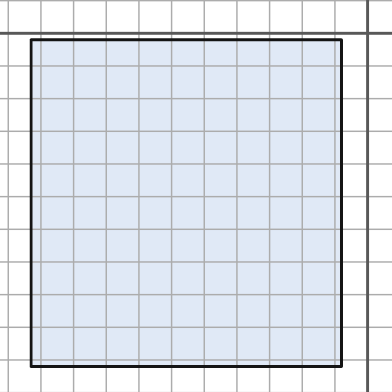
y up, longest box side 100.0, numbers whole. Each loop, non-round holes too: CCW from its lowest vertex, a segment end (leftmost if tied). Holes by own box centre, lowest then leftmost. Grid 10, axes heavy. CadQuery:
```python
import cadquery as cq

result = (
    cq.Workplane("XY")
    .moveTo(-103.0, -102.0)
    .lineTo(-8.0, -102.0)
    .lineTo(-8.0, -2.0)
    .lineTo(-103.0, -2.0)
    .close()
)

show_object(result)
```